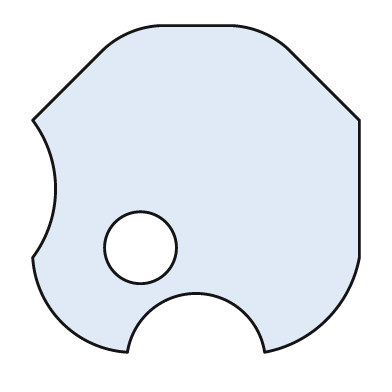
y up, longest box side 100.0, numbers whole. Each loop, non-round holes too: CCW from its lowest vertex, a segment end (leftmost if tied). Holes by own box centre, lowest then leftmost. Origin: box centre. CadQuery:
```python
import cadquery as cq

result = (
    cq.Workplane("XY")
    .moveTo(-21.0, -50.0)
    .threePointArc((0.0, -32.0), (21.0, -50.0))
    .threePointArc((40.0, -40.0), (50.0, -21.0))
    .lineTo(50.0, 21.0)
    .lineTo(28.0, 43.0)
    .threePointArc((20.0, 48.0), (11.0, 50.0))
    .lineTo(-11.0, 50.0)
    .threePointArc((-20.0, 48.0), (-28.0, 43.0))
    .lineTo(-50.0, 21.0)
    .threePointArc((-43.0, 0.0), (-50.0, -21.0))
    .threePointArc((-41.0, -41.0), (-21.0, -50.0))
    .close()
    .moveTo(-17.0, -18.0)
    .circle(11.0)
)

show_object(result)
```